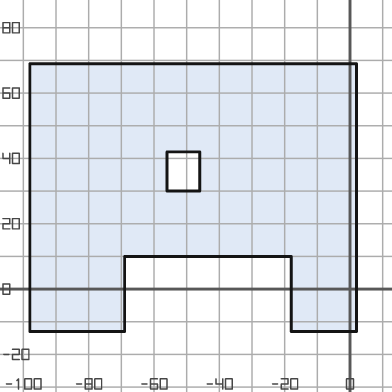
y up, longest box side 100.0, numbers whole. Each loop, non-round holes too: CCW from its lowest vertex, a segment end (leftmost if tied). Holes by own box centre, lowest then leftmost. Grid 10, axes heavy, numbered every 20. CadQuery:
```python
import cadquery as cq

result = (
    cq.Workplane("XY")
    .moveTo(-98.0, -13.0)
    .lineTo(-69.0, -13.0)
    .lineTo(-69.0, 10.0)
    .lineTo(-18.0, 10.0)
    .lineTo(-18.0, -13.0)
    .lineTo(2.0, -13.0)
    .lineTo(2.0, 69.0)
    .lineTo(-98.0, 69.0)
    .close()
    .moveTo(-56.0, 30.0)
    .lineTo(-46.0, 30.0)
    .lineTo(-46.0, 42.0)
    .lineTo(-56.0, 42.0)
    .close()
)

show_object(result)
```